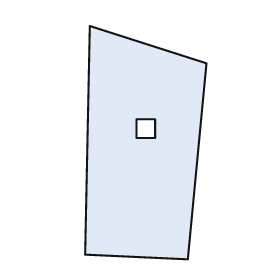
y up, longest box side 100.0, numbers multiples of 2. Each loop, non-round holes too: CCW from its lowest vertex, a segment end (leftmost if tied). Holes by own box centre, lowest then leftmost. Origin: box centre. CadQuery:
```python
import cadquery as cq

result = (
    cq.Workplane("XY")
    .moveTo(18.0, -50.0)
    .lineTo(26.0, 34.0)
    .lineTo(-24.0, 50.0)
    .lineTo(-26.0, -48.0)
    .close()
    .moveTo(-4.0, 2.0)
    .lineTo(4.0, 2.0)
    .lineTo(4.0, 10.0)
    .lineTo(-4.0, 10.0)
    .close()
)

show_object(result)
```